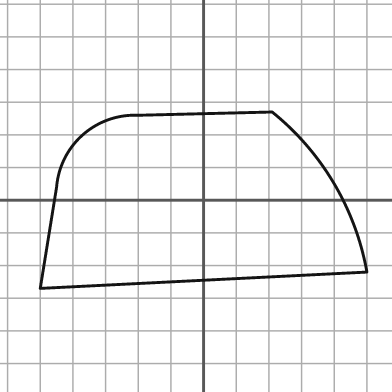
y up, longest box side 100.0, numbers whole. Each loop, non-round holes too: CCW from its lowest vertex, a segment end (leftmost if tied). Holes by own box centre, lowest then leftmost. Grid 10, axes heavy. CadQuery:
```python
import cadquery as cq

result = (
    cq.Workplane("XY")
    .moveTo(-50.0, -27.0)
    .lineTo(50.0, -22.0)
    .threePointArc((40.0, 5.0), (21.0, 27.0))
    .lineTo(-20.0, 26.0)
    .threePointArc((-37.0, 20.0), (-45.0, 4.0))
    .close()
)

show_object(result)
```